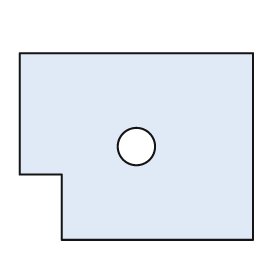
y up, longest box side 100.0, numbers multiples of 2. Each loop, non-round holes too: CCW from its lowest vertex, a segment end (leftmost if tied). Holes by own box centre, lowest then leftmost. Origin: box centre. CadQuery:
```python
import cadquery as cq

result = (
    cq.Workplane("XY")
    .moveTo(-32.0, -40.0)
    .lineTo(50.0, -40.0)
    .lineTo(50.0, 40.0)
    .lineTo(-50.0, 40.0)
    .lineTo(-50.0, -12.0)
    .lineTo(-32.0, -12.0)
    .close()
    .moveTo(0.0, 0.0)
    .circle(8.0)
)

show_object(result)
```